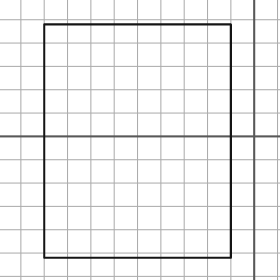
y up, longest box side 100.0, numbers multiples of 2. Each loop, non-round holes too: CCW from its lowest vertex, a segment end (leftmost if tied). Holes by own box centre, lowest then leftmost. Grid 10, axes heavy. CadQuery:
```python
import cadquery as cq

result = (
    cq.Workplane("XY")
    .moveTo(-90.0, -52.0)
    .lineTo(-10.0, -52.0)
    .lineTo(-10.0, 48.0)
    .lineTo(-90.0, 48.0)
    .close()
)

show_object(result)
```